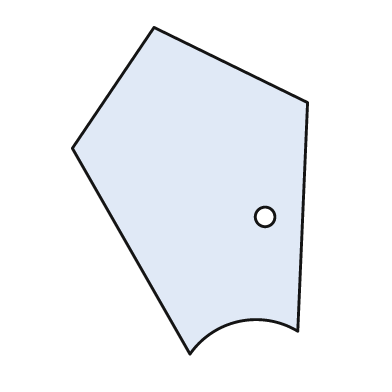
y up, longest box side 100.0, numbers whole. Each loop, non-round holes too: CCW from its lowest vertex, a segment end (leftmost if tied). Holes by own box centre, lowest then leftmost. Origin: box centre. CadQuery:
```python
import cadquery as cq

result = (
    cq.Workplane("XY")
    .moveTo(0.0, -50.0)
    .threePointArc((15.0, -40.0), (33.0, -43.0))
    .lineTo(36.0, 27.0)
    .lineTo(-11.0, 50.0)
    .lineTo(-36.0, 13.0)
    .close()
    .moveTo(23.0, -8.0)
    .circle(3.0)
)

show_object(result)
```